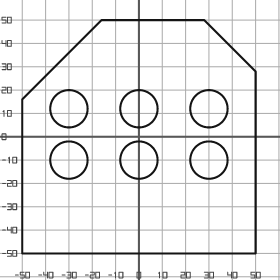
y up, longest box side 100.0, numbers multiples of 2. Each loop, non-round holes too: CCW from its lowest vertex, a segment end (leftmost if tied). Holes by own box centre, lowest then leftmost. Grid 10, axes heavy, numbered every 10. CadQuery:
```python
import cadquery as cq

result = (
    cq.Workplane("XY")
    .moveTo(-50.0, -50.0)
    .lineTo(50.0, -50.0)
    .lineTo(50.0, 28.0)
    .lineTo(28.0, 50.0)
    .lineTo(-16.0, 50.0)
    .lineTo(-50.0, 16.0)
    .close()
    .moveTo(-30.0, -10.0)
    .circle(8.0)
    .moveTo(0.0, -10.0)
    .circle(8.0)
    .moveTo(30.0, -10.0)
    .circle(8.0)
    .moveTo(-30.0, 12.0)
    .circle(8.0)
    .moveTo(0.0, 12.0)
    .circle(8.0)
    .moveTo(30.0, 12.0)
    .circle(8.0)
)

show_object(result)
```